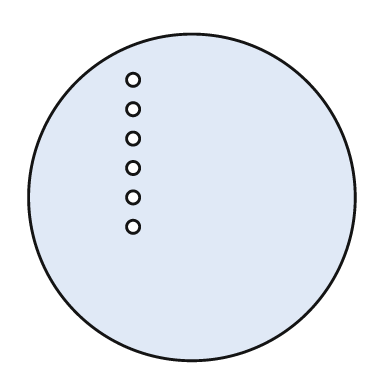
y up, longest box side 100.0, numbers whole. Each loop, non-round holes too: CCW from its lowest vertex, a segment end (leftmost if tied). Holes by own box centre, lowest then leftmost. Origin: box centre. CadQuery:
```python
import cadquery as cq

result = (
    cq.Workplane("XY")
    .moveTo(0.0, 0.0)
    .circle(50.0)
    .moveTo(-18.0, -9.0)
    .circle(2.0)
    .moveTo(-18.0, 0.0)
    .circle(2.0)
    .moveTo(-18.0, 9.0)
    .circle(2.0)
    .moveTo(-18.0, 18.0)
    .circle(2.0)
    .moveTo(-18.0, 27.0)
    .circle(2.0)
    .moveTo(-18.0, 36.0)
    .circle(2.0)
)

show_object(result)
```